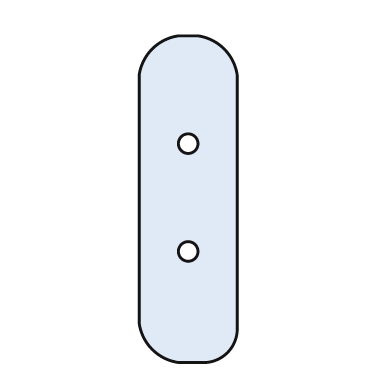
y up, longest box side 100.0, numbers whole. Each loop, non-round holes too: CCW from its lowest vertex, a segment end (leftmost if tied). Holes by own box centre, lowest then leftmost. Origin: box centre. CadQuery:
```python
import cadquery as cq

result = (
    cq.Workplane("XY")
    .moveTo(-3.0, -50.0)
    .lineTo(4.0, -50.0)
    .threePointArc((12.0, -47.0), (15.0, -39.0))
    .lineTo(15.0, 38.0)
    .threePointArc((11.0, 46.0), (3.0, 50.0))
    .lineTo(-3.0, 50.0)
    .threePointArc((-11.0, 46.0), (-15.0, 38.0))
    .lineTo(-15.0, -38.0)
    .threePointArc((-11.0, -46.0), (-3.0, -50.0))
    .close()
    .moveTo(0.0, -16.0)
    .circle(3.0)
    .moveTo(0.0, 17.0)
    .circle(3.0)
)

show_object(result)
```